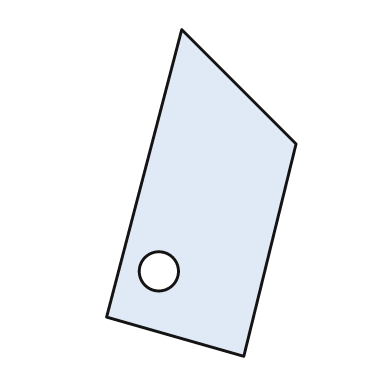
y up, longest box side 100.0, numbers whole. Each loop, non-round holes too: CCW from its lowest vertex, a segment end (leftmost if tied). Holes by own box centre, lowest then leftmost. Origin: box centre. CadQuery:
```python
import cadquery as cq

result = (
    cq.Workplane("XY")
    .moveTo(13.0, -50.0)
    .lineTo(29.0, 15.0)
    .lineTo(-6.0, 50.0)
    .lineTo(-29.0, -38.0)
    .close()
    .moveTo(-13.0, -24.0)
    .circle(6.0)
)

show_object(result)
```